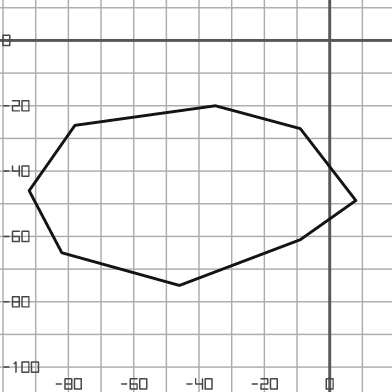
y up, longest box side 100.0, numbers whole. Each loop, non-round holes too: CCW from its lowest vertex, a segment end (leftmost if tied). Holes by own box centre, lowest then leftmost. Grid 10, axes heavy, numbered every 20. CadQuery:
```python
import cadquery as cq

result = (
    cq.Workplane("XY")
    .moveTo(-46.0, -75.0)
    .lineTo(-9.0, -61.0)
    .lineTo(8.0, -49.0)
    .lineTo(-9.0, -27.0)
    .lineTo(-35.0, -20.0)
    .lineTo(-78.0, -26.0)
    .lineTo(-92.0, -46.0)
    .lineTo(-82.0, -65.0)
    .close()
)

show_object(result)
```